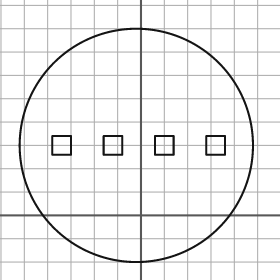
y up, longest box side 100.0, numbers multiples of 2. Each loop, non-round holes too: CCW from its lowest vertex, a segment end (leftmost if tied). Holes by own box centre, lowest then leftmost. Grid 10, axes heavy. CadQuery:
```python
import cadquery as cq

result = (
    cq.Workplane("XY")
    .moveTo(-2.0, 30.0)
    .circle(50.0)
    .moveTo(-38.0, 26.0)
    .lineTo(-30.0, 26.0)
    .lineTo(-30.0, 34.0)
    .lineTo(-38.0, 34.0)
    .close()
    .moveTo(-16.0, 26.0)
    .lineTo(-8.0, 26.0)
    .lineTo(-8.0, 34.0)
    .lineTo(-16.0, 34.0)
    .close()
    .moveTo(6.0, 26.0)
    .lineTo(14.0, 26.0)
    .lineTo(14.0, 34.0)
    .lineTo(6.0, 34.0)
    .close()
    .moveTo(28.0, 26.0)
    .lineTo(36.0, 26.0)
    .lineTo(36.0, 34.0)
    .lineTo(28.0, 34.0)
    .close()
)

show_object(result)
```